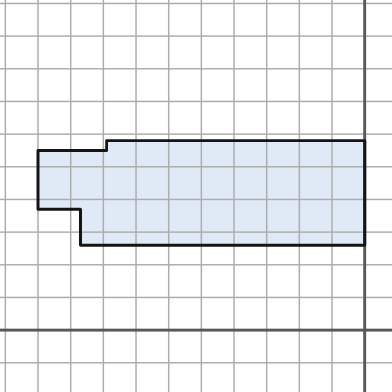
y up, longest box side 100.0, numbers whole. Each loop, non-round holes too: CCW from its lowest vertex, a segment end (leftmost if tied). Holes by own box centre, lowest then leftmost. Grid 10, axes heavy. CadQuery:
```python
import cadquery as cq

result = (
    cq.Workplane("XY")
    .moveTo(-87.0, 26.0)
    .lineTo(0.0, 26.0)
    .lineTo(0.0, 58.0)
    .lineTo(-79.0, 58.0)
    .lineTo(-79.0, 55.0)
    .lineTo(-100.0, 55.0)
    .lineTo(-100.0, 37.0)
    .lineTo(-87.0, 37.0)
    .close()
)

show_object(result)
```